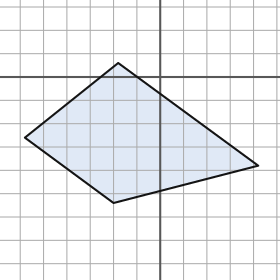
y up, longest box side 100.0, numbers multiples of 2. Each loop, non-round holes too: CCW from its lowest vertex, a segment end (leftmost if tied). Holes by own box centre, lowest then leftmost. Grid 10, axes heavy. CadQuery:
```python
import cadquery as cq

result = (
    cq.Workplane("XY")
    .moveTo(-20.0, -54.0)
    .lineTo(42.0, -38.0)
    .lineTo(-18.0, 6.0)
    .lineTo(-58.0, -26.0)
    .close()
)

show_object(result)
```